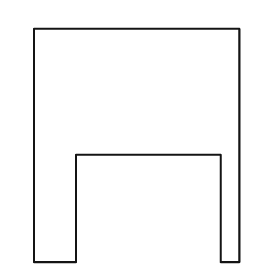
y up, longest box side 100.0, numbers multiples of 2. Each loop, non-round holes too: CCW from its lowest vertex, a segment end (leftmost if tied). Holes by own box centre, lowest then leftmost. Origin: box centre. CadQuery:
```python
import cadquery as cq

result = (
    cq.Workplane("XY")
    .moveTo(-44.0, -50.0)
    .lineTo(-26.0, -50.0)
    .lineTo(-26.0, -4.0)
    .lineTo(36.0, -4.0)
    .lineTo(36.0, -50.0)
    .lineTo(44.0, -50.0)
    .lineTo(44.0, 50.0)
    .lineTo(-44.0, 50.0)
    .close()
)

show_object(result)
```